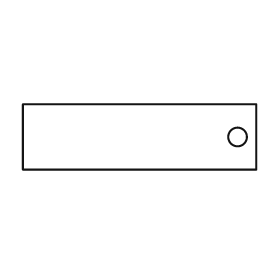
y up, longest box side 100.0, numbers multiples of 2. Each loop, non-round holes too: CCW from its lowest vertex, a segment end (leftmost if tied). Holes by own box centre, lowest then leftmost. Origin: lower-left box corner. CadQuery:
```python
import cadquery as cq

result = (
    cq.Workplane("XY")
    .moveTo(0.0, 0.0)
    .lineTo(100.0, 0.0)
    .lineTo(100.0, 28.0)
    .lineTo(0.0, 28.0)
    .close()
    .moveTo(92.0, 14.0)
    .circle(4.0)
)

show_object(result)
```